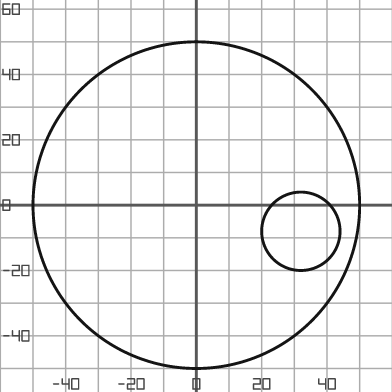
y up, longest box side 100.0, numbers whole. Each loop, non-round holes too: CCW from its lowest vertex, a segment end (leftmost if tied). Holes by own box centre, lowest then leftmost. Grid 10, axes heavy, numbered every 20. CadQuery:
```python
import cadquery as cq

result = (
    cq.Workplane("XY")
    .moveTo(0.0, 0.0)
    .circle(50.0)
    .moveTo(32.0, -8.0)
    .circle(12.0)
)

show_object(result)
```